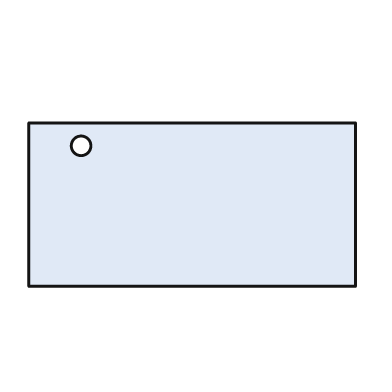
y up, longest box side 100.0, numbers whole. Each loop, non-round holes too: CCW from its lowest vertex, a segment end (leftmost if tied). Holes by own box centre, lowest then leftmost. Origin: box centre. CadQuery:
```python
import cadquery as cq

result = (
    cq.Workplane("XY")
    .moveTo(-50.0, -25.0)
    .lineTo(50.0, -25.0)
    .lineTo(50.0, 25.0)
    .lineTo(-50.0, 25.0)
    .close()
    .moveTo(-34.0, 18.0)
    .circle(3.0)
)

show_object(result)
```